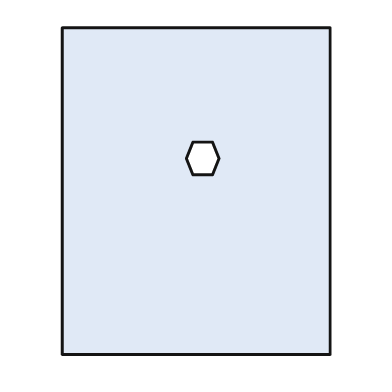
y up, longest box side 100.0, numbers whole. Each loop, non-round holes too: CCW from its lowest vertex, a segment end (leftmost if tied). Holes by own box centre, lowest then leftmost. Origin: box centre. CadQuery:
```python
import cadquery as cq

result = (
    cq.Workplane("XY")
    .moveTo(-41.0, -50.0)
    .lineTo(41.0, -50.0)
    .lineTo(41.0, 50.0)
    .lineTo(-41.0, 50.0)
    .close()
    .moveTo(-1.0, 5.0)
    .lineTo(5.0, 5.0)
    .lineTo(7.0, 10.0)
    .lineTo(5.0, 15.0)
    .lineTo(-1.0, 15.0)
    .lineTo(-3.0, 10.0)
    .close()
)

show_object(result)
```